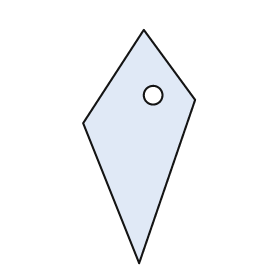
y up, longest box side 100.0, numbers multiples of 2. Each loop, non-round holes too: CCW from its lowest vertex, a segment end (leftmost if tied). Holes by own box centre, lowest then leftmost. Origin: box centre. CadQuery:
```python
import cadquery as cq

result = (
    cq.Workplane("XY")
    .moveTo(0.0, -50.0)
    .lineTo(24.0, 20.0)
    .lineTo(2.0, 50.0)
    .lineTo(-24.0, 10.0)
    .close()
    .moveTo(6.0, 22.0)
    .circle(4.0)
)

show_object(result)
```